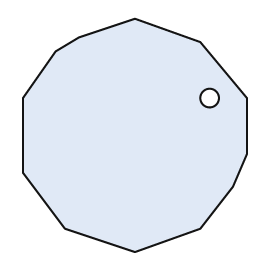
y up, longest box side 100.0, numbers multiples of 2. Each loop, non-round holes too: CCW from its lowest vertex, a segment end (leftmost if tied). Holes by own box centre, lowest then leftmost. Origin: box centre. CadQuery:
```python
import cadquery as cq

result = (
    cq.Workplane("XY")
    .moveTo(0.0, -50.0)
    .lineTo(28.0, -40.0)
    .lineTo(42.0, -22.0)
    .lineTo(48.0, -8.0)
    .lineTo(48.0, 16.0)
    .lineTo(28.0, 40.0)
    .lineTo(0.0, 50.0)
    .lineTo(-24.0, 42.0)
    .lineTo(-34.0, 36.0)
    .lineTo(-48.0, 16.0)
    .lineTo(-48.0, -16.0)
    .lineTo(-30.0, -40.0)
    .close()
    .moveTo(32.0, 16.0)
    .circle(4.0)
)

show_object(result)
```